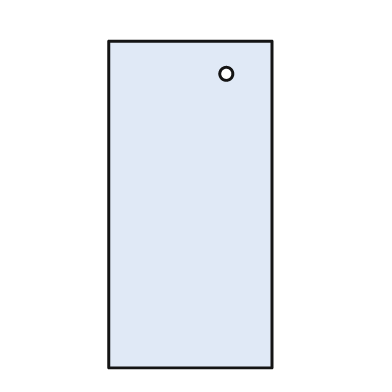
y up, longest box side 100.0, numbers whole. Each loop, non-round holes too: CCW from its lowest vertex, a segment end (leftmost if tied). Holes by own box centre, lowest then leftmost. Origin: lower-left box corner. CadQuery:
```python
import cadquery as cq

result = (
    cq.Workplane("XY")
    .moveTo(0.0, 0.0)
    .lineTo(50.0, 0.0)
    .lineTo(50.0, 100.0)
    .lineTo(0.0, 100.0)
    .close()
    .moveTo(36.0, 90.0)
    .circle(2.0)
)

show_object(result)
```